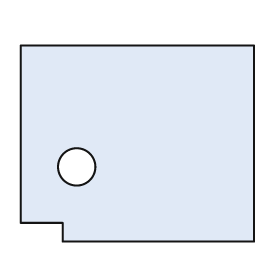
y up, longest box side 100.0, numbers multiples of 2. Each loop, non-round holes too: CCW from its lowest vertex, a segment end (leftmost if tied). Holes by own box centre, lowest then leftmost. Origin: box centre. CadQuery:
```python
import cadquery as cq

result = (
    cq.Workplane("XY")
    .moveTo(-32.0, -42.0)
    .lineTo(50.0, -42.0)
    .lineTo(50.0, 42.0)
    .lineTo(-50.0, 42.0)
    .lineTo(-50.0, -34.0)
    .lineTo(-32.0, -34.0)
    .close()
    .moveTo(-26.0, -10.0)
    .circle(8.0)
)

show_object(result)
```